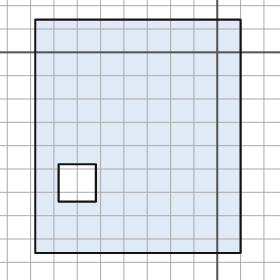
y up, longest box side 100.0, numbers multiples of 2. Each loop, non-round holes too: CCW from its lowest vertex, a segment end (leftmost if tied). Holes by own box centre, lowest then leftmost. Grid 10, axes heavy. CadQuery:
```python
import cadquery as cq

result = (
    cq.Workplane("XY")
    .moveTo(-78.0, -86.0)
    .lineTo(10.0, -86.0)
    .lineTo(10.0, 14.0)
    .lineTo(-78.0, 14.0)
    .close()
    .moveTo(-68.0, -64.0)
    .lineTo(-52.0, -64.0)
    .lineTo(-52.0, -48.0)
    .lineTo(-68.0, -48.0)
    .close()
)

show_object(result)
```